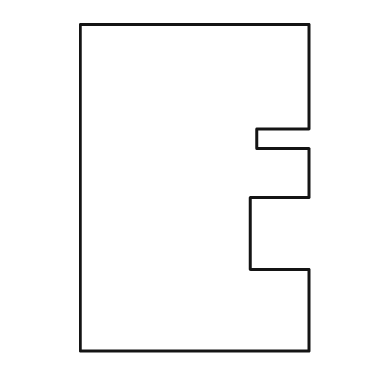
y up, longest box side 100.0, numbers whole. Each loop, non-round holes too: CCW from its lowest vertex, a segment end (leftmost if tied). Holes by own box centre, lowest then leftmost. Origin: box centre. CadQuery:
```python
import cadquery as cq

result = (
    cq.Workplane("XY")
    .moveTo(-35.0, -50.0)
    .lineTo(35.0, -50.0)
    .lineTo(35.0, -25.0)
    .lineTo(17.0, -25.0)
    .lineTo(17.0, -3.0)
    .lineTo(35.0, -3.0)
    .lineTo(35.0, 12.0)
    .lineTo(19.0, 12.0)
    .lineTo(19.0, 18.0)
    .lineTo(35.0, 18.0)
    .lineTo(35.0, 50.0)
    .lineTo(-35.0, 50.0)
    .close()
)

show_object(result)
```